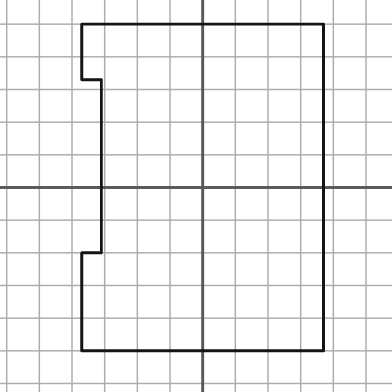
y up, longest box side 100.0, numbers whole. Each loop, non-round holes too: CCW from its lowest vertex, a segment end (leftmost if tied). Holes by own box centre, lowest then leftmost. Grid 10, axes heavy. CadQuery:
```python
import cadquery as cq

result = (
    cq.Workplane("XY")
    .moveTo(-37.0, -50.0)
    .lineTo(37.0, -50.0)
    .lineTo(37.0, 50.0)
    .lineTo(-37.0, 50.0)
    .lineTo(-37.0, 33.0)
    .lineTo(-31.0, 33.0)
    .lineTo(-31.0, -20.0)
    .lineTo(-37.0, -20.0)
    .close()
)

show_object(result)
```